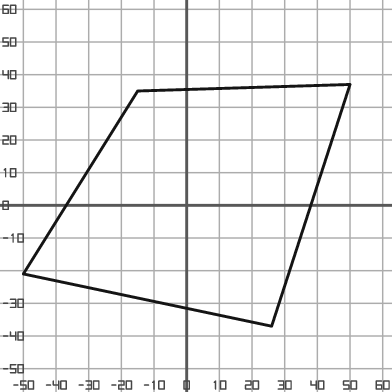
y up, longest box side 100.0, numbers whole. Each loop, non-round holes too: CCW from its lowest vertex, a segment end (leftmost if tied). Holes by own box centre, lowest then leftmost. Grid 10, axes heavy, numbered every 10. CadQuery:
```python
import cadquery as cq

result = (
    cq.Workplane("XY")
    .moveTo(26.0, -37.0)
    .lineTo(50.0, 37.0)
    .lineTo(-15.0, 35.0)
    .lineTo(-50.0, -21.0)
    .close()
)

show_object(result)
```